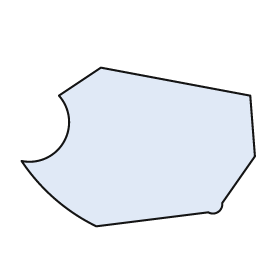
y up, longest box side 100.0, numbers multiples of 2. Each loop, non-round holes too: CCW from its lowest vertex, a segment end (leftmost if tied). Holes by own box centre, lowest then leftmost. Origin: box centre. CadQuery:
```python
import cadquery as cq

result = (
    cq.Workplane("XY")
    .moveTo(-18.0, -34.0)
    .lineTo(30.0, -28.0)
    .threePointArc((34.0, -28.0), (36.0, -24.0))
    .lineTo(50.0, -4.0)
    .lineTo(48.0, 22.0)
    .lineTo(-16.0, 34.0)
    .lineTo(-34.0, 22.0)
    .threePointArc((-32.0, 2.0), (-50.0, -6.0))
    .threePointArc((-36.0, -22.0), (-18.0, -34.0))
    .close()
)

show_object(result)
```